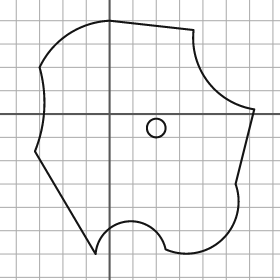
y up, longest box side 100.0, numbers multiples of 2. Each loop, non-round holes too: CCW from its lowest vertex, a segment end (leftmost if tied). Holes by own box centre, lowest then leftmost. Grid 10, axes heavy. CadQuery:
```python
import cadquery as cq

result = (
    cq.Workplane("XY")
    .moveTo(-6.0, -60.0)
    .threePointArc((8.0, -46.0), (24.0, -58.0))
    .threePointArc((48.0, -54.0), (54.0, -30.0))
    .lineTo(62.0, 2.0)
    .threePointArc((42.0, 14.0), (36.0, 36.0))
    .lineTo(0.0, 40.0)
    .threePointArc((-18.0, 34.0), (-30.0, 20.0))
    .threePointArc((-28.0, 2.0), (-32.0, -16.0))
    .close()
    .moveTo(20.0, -6.0)
    .circle(4.0)
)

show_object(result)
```